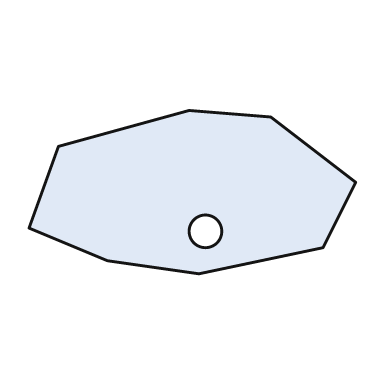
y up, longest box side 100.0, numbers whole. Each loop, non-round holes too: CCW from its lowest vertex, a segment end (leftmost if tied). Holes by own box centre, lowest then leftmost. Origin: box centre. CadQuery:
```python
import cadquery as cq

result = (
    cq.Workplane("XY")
    .moveTo(2.0, -25.0)
    .lineTo(40.0, -17.0)
    .lineTo(50.0, 3.0)
    .lineTo(24.0, 23.0)
    .lineTo(-1.0, 25.0)
    .lineTo(-41.0, 14.0)
    .lineTo(-50.0, -11.0)
    .lineTo(-26.0, -21.0)
    .close()
    .moveTo(4.0, -12.0)
    .circle(5.0)
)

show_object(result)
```